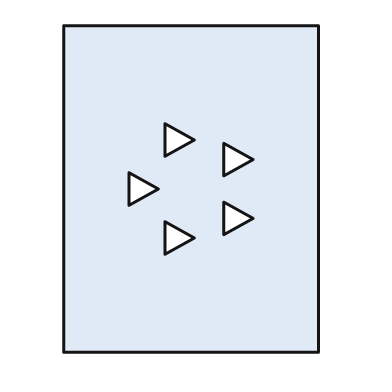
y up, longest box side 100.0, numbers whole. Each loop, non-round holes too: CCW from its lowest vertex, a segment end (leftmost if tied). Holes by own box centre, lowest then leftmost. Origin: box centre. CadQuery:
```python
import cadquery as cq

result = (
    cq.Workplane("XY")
    .moveTo(-39.0, -50.0)
    .lineTo(39.0, -50.0)
    .lineTo(39.0, 50.0)
    .lineTo(-39.0, 50.0)
    .close()
    .moveTo(-8.0, -20.0)
    .lineTo(1.0, -15.0)
    .lineTo(-8.0, -10.0)
    .close()
    .moveTo(10.0, -14.0)
    .lineTo(19.0, -9.0)
    .lineTo(10.0, -4.0)
    .close()
    .moveTo(-19.0, -5.0)
    .lineTo(-10.0, 0.0)
    .lineTo(-19.0, 5.0)
    .close()
    .moveTo(10.0, 4.0)
    .lineTo(19.0, 9.0)
    .lineTo(10.0, 14.0)
    .close()
    .moveTo(-8.0, 10.0)
    .lineTo(1.0, 15.0)
    .lineTo(-8.0, 20.0)
    .close()
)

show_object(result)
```